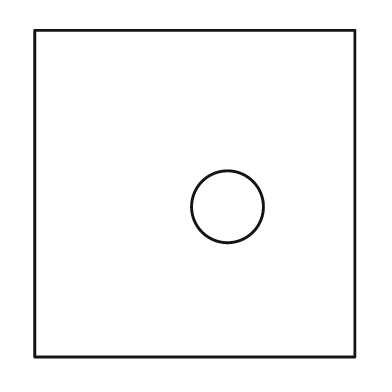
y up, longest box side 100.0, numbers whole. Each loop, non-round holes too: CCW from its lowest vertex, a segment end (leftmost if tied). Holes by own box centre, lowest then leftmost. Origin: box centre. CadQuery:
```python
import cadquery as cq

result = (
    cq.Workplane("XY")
    .moveTo(-49.0, -50.0)
    .lineTo(49.0, -50.0)
    .lineTo(49.0, 50.0)
    .lineTo(-49.0, 50.0)
    .close()
    .moveTo(10.0, -4.0)
    .circle(11.0)
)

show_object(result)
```